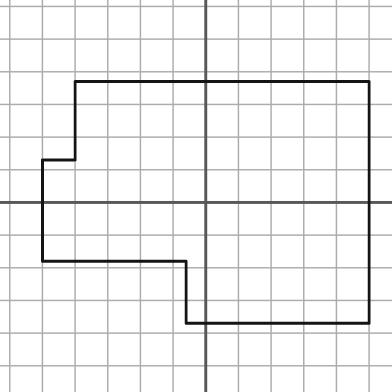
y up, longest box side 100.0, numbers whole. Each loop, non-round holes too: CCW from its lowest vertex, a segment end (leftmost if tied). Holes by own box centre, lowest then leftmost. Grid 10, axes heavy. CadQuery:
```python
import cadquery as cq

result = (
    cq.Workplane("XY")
    .moveTo(-6.0, -37.0)
    .lineTo(50.0, -37.0)
    .lineTo(50.0, 37.0)
    .lineTo(-40.0, 37.0)
    .lineTo(-40.0, 13.0)
    .lineTo(-50.0, 13.0)
    .lineTo(-50.0, -18.0)
    .lineTo(-6.0, -18.0)
    .close()
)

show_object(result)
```